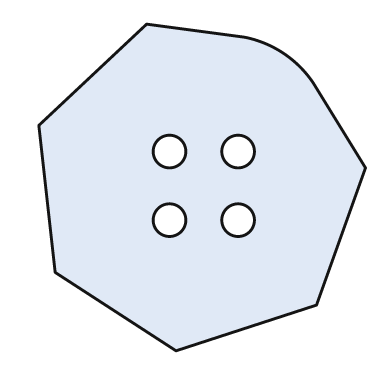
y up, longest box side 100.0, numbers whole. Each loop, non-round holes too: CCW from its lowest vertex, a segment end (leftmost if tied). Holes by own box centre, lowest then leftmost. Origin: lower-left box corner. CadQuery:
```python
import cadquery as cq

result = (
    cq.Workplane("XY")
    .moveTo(42.0, 0.0)
    .lineTo(85.0, 14.0)
    .lineTo(100.0, 56.0)
    .lineTo(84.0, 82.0)
    .threePointArc((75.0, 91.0), (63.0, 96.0))
    .lineTo(33.0, 100.0)
    .lineTo(0.0, 69.0)
    .lineTo(5.0, 24.0)
    .close()
    .moveTo(40.0, 40.0)
    .circle(5.0)
    .moveTo(61.0, 40.0)
    .circle(5.0)
    .moveTo(40.0, 61.0)
    .circle(5.0)
    .moveTo(61.0, 61.0)
    .circle(5.0)
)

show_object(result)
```